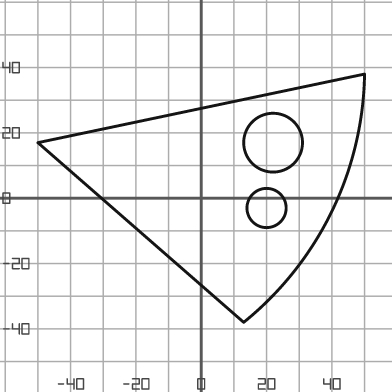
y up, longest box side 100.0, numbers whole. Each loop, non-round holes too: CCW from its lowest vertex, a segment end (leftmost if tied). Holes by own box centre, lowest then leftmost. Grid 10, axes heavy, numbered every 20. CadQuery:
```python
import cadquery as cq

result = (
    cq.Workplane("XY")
    .moveTo(13.0, -38.0)
    .threePointArc((40.0, -4.0), (50.0, 38.0))
    .lineTo(-50.0, 17.0)
    .close()
    .moveTo(20.0, -3.0)
    .circle(6.0)
    .moveTo(22.0, 17.0)
    .circle(9.0)
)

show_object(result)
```